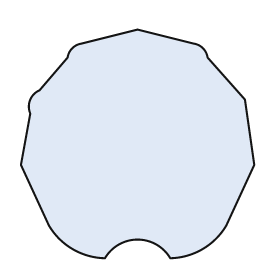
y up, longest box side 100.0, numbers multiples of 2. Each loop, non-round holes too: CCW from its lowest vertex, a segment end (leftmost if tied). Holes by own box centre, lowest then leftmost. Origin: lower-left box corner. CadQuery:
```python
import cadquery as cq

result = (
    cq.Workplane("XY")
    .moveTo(36.0, 0.0)
    .threePointArc((50.0, 8.0), (64.0, 0.0))
    .threePointArc((78.0, 4.0), (88.0, 14.0))
    .lineTo(100.0, 40.0)
    .lineTo(96.0, 68.0)
    .lineTo(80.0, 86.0)
    .threePointArc((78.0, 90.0), (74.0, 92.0))
    .lineTo(50.0, 98.0)
    .lineTo(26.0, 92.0)
    .threePointArc((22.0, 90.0), (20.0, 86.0))
    .lineTo(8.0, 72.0)
    .threePointArc((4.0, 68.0), (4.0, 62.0))
    .lineTo(0.0, 40.0)
    .lineTo(12.0, 14.0)
    .threePointArc((22.0, 4.0), (36.0, 0.0))
    .close()
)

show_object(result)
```